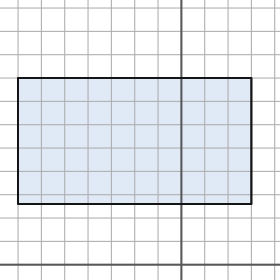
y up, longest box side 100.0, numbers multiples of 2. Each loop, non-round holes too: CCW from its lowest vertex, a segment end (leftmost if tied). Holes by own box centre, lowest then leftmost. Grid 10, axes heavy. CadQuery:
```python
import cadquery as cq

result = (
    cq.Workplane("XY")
    .moveTo(-70.0, 26.0)
    .lineTo(30.0, 26.0)
    .lineTo(30.0, 80.0)
    .lineTo(-70.0, 80.0)
    .close()
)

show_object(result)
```